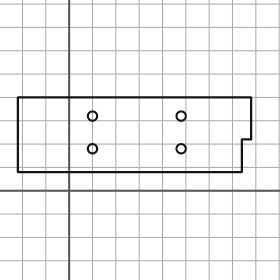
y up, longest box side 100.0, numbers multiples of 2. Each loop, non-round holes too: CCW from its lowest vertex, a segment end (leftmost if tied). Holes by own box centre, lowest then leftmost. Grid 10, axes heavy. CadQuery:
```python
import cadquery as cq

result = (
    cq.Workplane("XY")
    .moveTo(-22.0, 8.0)
    .lineTo(74.0, 8.0)
    .lineTo(74.0, 22.0)
    .lineTo(78.0, 22.0)
    .lineTo(78.0, 40.0)
    .lineTo(-22.0, 40.0)
    .close()
    .moveTo(10.0, 18.0)
    .circle(2.0)
    .moveTo(48.0, 18.0)
    .circle(2.0)
    .moveTo(10.0, 32.0)
    .circle(2.0)
    .moveTo(48.0, 32.0)
    .circle(2.0)
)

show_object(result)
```